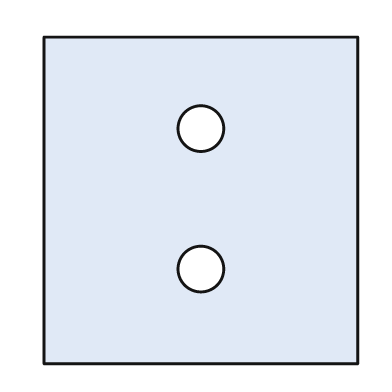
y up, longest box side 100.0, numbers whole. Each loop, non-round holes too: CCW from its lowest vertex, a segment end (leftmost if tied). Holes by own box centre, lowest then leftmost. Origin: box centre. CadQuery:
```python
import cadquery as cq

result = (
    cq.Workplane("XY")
    .moveTo(-48.0, -50.0)
    .lineTo(48.0, -50.0)
    .lineTo(48.0, 50.0)
    .lineTo(-48.0, 50.0)
    .close()
    .moveTo(0.0, -21.0)
    .circle(7.0)
    .moveTo(0.0, 22.0)
    .circle(7.0)
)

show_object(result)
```